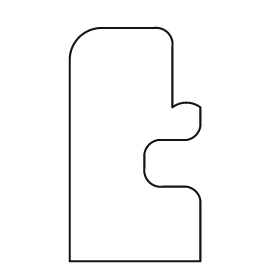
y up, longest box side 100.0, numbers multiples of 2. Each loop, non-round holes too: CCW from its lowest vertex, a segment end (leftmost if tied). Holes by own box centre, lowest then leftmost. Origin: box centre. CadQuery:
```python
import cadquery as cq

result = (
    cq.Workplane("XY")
    .moveTo(-28.0, -50.0)
    .lineTo(28.0, -50.0)
    .lineTo(28.0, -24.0)
    .threePointArc((26.0, -20.0), (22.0, -18.0))
    .lineTo(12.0, -18.0)
    .threePointArc((6.0, -16.0), (4.0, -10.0))
    .lineTo(4.0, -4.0)
    .threePointArc((6.0, 0.0), (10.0, 2.0))
    .lineTo(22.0, 2.0)
    .threePointArc((26.0, 4.0), (28.0, 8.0))
    .lineTo(28.0, 16.0)
    .threePointArc((22.0, 18.0), (16.0, 16.0))
    .lineTo(16.0, 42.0)
    .threePointArc((14.0, 48.0), (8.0, 50.0))
    .lineTo(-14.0, 50.0)
    .threePointArc((-24.0, 46.0), (-28.0, 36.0))
    .close()
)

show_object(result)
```